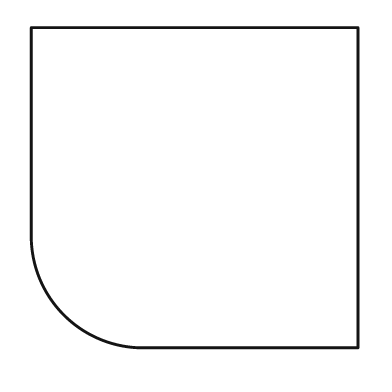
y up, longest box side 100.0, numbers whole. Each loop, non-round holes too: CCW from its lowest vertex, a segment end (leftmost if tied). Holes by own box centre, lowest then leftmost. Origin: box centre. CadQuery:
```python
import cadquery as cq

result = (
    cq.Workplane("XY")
    .moveTo(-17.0, -49.0)
    .lineTo(50.0, -49.0)
    .lineTo(50.0, 49.0)
    .lineTo(-50.0, 49.0)
    .lineTo(-50.0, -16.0)
    .threePointArc((-40.0, -39.0), (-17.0, -49.0))
    .close()
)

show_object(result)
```